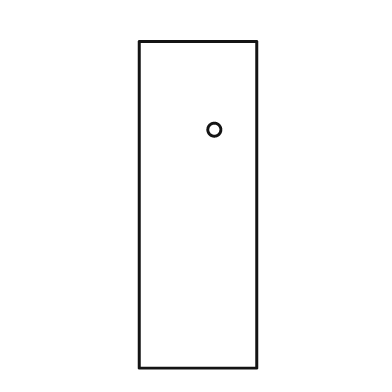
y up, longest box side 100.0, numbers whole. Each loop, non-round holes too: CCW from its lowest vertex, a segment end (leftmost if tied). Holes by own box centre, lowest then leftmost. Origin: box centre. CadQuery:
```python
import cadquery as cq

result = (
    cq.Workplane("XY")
    .moveTo(-18.0, -50.0)
    .lineTo(18.0, -50.0)
    .lineTo(18.0, 50.0)
    .lineTo(-18.0, 50.0)
    .close()
    .moveTo(5.0, 23.0)
    .circle(2.0)
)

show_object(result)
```